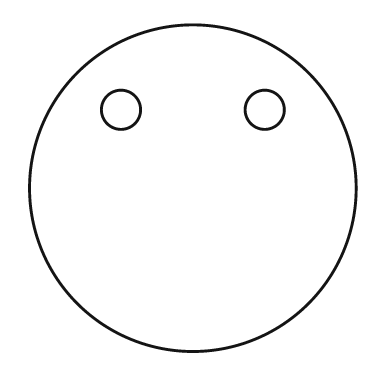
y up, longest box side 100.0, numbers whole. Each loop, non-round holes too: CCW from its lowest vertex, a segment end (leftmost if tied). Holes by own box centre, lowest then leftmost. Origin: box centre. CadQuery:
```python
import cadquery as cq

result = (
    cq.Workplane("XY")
    .moveTo(0.0, 0.0)
    .circle(50.0)
    .moveTo(-22.0, 24.0)
    .circle(6.0)
    .moveTo(22.0, 24.0)
    .circle(6.0)
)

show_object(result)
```